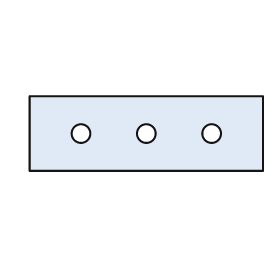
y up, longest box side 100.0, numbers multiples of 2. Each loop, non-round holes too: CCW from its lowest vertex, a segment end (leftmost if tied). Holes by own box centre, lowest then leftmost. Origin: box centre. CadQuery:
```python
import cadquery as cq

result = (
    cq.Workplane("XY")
    .moveTo(-50.0, -16.0)
    .lineTo(50.0, -16.0)
    .lineTo(50.0, 16.0)
    .lineTo(-50.0, 16.0)
    .close()
    .moveTo(-28.0, 0.0)
    .circle(4.0)
    .moveTo(0.0, 0.0)
    .circle(4.0)
    .moveTo(28.0, 0.0)
    .circle(4.0)
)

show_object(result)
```